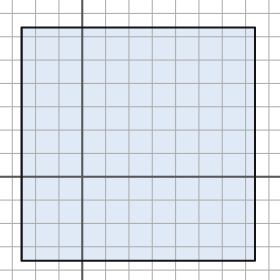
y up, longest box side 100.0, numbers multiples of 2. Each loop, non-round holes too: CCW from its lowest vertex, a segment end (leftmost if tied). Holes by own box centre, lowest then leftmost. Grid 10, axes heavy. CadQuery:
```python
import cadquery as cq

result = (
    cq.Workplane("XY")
    .moveTo(-26.0, -36.0)
    .lineTo(74.0, -36.0)
    .lineTo(74.0, 64.0)
    .lineTo(-26.0, 64.0)
    .close()
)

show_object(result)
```